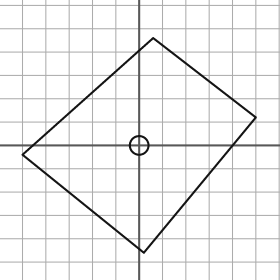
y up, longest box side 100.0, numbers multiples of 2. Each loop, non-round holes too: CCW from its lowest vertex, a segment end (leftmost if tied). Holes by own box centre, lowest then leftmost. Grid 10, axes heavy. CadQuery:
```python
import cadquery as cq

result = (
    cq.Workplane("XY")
    .moveTo(2.0, -46.0)
    .lineTo(50.0, 12.0)
    .lineTo(6.0, 46.0)
    .lineTo(-50.0, -4.0)
    .close()
    .moveTo(0.0, 0.0)
    .circle(4.0)
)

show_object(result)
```